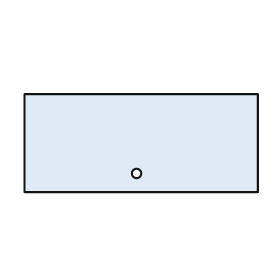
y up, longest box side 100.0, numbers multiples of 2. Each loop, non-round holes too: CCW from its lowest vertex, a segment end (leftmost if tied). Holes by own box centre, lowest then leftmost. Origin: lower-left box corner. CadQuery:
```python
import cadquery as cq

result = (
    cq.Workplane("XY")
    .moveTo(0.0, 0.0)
    .lineTo(100.0, 0.0)
    .lineTo(100.0, 42.0)
    .lineTo(0.0, 42.0)
    .close()
    .moveTo(48.0, 8.0)
    .circle(2.0)
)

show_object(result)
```